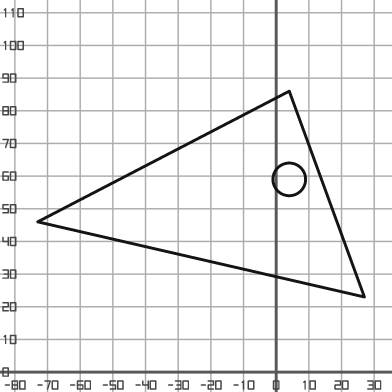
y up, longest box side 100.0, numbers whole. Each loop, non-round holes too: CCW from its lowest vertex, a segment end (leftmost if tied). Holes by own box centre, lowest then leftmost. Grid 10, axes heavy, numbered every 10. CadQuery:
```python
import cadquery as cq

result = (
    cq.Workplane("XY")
    .moveTo(27.0, 23.0)
    .lineTo(4.0, 86.0)
    .lineTo(-73.0, 46.0)
    .close()
    .moveTo(4.0, 59.0)
    .circle(5.0)
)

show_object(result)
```